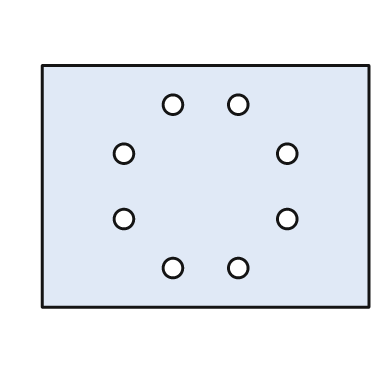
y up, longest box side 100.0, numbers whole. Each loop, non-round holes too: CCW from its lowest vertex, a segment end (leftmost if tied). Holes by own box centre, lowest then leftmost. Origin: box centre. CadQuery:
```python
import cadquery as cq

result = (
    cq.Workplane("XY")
    .moveTo(-50.0, -37.0)
    .lineTo(50.0, -37.0)
    .lineTo(50.0, 37.0)
    .lineTo(-50.0, 37.0)
    .close()
    .moveTo(-10.0, -25.0)
    .circle(3.0)
    .moveTo(10.0, -25.0)
    .circle(3.0)
    .moveTo(-25.0, -10.0)
    .circle(3.0)
    .moveTo(25.0, -10.0)
    .circle(3.0)
    .moveTo(-25.0, 10.0)
    .circle(3.0)
    .moveTo(25.0, 10.0)
    .circle(3.0)
    .moveTo(-10.0, 25.0)
    .circle(3.0)
    .moveTo(10.0, 25.0)
    .circle(3.0)
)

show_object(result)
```